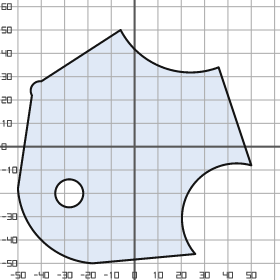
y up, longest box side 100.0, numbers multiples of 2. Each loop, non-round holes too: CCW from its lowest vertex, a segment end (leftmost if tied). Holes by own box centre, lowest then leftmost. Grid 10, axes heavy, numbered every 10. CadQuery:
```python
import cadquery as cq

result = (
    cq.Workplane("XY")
    .moveTo(-18.0, -50.0)
    .lineTo(26.0, -46.0)
    .threePointArc((24.0, -18.0), (50.0, -8.0))
    .lineTo(36.0, 34.0)
    .threePointArc((12.0, 34.0), (-6.0, 50.0))
    .lineTo(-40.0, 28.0)
    .threePointArc((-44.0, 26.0), (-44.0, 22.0))
    .lineTo(-50.0, -18.0)
    .threePointArc((-40.0, -40.0), (-18.0, -50.0))
    .close()
    .moveTo(-28.0, -20.0)
    .circle(6.0)
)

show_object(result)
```